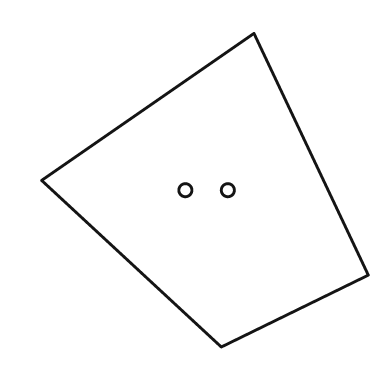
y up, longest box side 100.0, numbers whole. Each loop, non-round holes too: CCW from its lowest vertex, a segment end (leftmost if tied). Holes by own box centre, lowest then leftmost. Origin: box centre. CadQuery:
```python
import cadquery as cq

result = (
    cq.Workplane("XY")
    .moveTo(5.0, -48.0)
    .lineTo(50.0, -26.0)
    .lineTo(15.0, 48.0)
    .lineTo(-50.0, 3.0)
    .close()
    .moveTo(-6.0, 0.0)
    .circle(2.0)
    .moveTo(7.0, 0.0)
    .circle(2.0)
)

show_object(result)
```